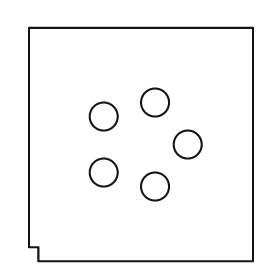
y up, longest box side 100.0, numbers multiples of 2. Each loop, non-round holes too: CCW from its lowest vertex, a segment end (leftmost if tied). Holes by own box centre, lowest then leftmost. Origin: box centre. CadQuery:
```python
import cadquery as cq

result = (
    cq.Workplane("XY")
    .moveTo(-44.0, -50.0)
    .lineTo(48.0, -50.0)
    .lineTo(48.0, 50.0)
    .lineTo(-48.0, 50.0)
    .lineTo(-48.0, -44.0)
    .lineTo(-44.0, -44.0)
    .close()
    .moveTo(6.0, -18.0)
    .circle(6.0)
    .moveTo(-16.0, -12.0)
    .circle(6.0)
    .moveTo(20.0, 0.0)
    .circle(6.0)
    .moveTo(-16.0, 12.0)
    .circle(6.0)
    .moveTo(6.0, 18.0)
    .circle(6.0)
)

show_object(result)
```